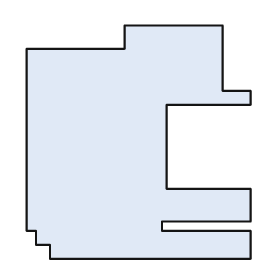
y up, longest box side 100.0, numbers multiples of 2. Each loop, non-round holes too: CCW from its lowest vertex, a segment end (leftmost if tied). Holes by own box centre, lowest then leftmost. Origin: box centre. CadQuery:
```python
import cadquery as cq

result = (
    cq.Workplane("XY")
    .moveTo(-38.0, -50.0)
    .lineTo(48.0, -50.0)
    .lineTo(48.0, -38.0)
    .lineTo(10.0, -38.0)
    .lineTo(10.0, -34.0)
    .lineTo(48.0, -34.0)
    .lineTo(48.0, -20.0)
    .lineTo(12.0, -20.0)
    .lineTo(12.0, 16.0)
    .lineTo(48.0, 16.0)
    .lineTo(48.0, 22.0)
    .lineTo(36.0, 22.0)
    .lineTo(36.0, 50.0)
    .lineTo(-6.0, 50.0)
    .lineTo(-6.0, 40.0)
    .lineTo(-48.0, 40.0)
    .lineTo(-48.0, -38.0)
    .lineTo(-44.0, -38.0)
    .lineTo(-44.0, -44.0)
    .lineTo(-38.0, -44.0)
    .close()
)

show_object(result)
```